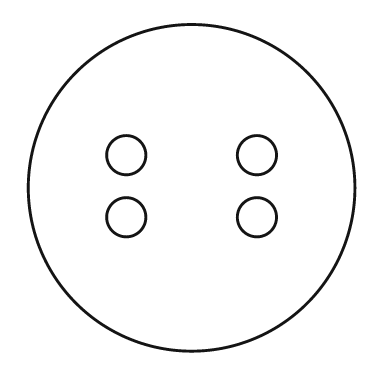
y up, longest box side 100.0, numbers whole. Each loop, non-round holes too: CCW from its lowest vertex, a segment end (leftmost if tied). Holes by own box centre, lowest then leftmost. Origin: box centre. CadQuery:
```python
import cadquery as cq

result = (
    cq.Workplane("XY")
    .moveTo(0.0, 0.0)
    .circle(50.0)
    .moveTo(-20.0, -9.0)
    .circle(6.0)
    .moveTo(20.0, -9.0)
    .circle(6.0)
    .moveTo(-20.0, 10.0)
    .circle(6.0)
    .moveTo(20.0, 10.0)
    .circle(6.0)
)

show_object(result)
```